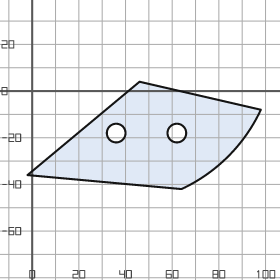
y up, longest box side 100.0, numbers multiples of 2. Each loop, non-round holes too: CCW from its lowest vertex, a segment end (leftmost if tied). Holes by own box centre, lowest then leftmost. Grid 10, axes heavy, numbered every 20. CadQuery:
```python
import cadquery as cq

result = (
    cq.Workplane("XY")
    .moveTo(64.0, -42.0)
    .threePointArc((84.0, -28.0), (98.0, -8.0))
    .lineTo(46.0, 4.0)
    .lineTo(-2.0, -36.0)
    .close()
    .moveTo(36.0, -18.0)
    .circle(4.0)
    .moveTo(62.0, -18.0)
    .circle(4.0)
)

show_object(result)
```